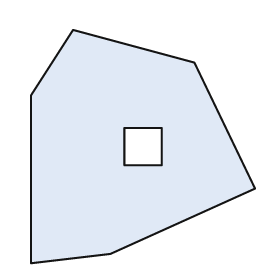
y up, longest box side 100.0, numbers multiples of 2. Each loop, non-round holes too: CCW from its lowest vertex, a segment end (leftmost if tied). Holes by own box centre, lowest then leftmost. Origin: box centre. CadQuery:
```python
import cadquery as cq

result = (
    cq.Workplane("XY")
    .moveTo(-48.0, -50.0)
    .lineTo(-14.0, -46.0)
    .lineTo(48.0, -18.0)
    .lineTo(22.0, 36.0)
    .lineTo(-30.0, 50.0)
    .lineTo(-48.0, 22.0)
    .close()
    .moveTo(-8.0, -8.0)
    .lineTo(8.0, -8.0)
    .lineTo(8.0, 8.0)
    .lineTo(-8.0, 8.0)
    .close()
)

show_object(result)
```